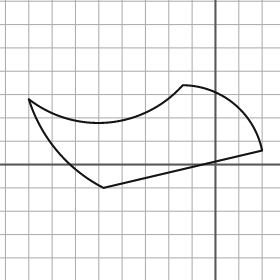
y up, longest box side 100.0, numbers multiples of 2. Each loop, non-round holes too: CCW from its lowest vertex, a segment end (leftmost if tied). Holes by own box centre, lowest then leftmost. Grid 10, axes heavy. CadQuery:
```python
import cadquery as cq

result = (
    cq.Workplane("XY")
    .moveTo(-48.0, -10.0)
    .lineTo(20.0, 6.0)
    .threePointArc((8.0, 26.0), (-14.0, 34.0))
    .threePointArc((-46.0, 18.0), (-80.0, 28.0))
    .threePointArc((-68.0, 6.0), (-48.0, -10.0))
    .close()
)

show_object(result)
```